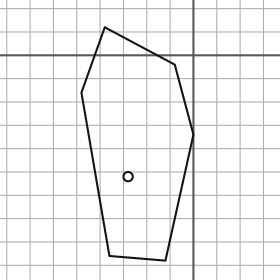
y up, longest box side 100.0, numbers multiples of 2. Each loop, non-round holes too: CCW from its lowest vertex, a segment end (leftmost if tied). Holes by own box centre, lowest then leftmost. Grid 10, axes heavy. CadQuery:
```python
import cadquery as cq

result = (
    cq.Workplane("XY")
    .moveTo(-12.0, -88.0)
    .lineTo(0.0, -34.0)
    .lineTo(-8.0, -4.0)
    .lineTo(-38.0, 12.0)
    .lineTo(-48.0, -16.0)
    .lineTo(-36.0, -86.0)
    .close()
    .moveTo(-28.0, -52.0)
    .circle(2.0)
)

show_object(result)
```